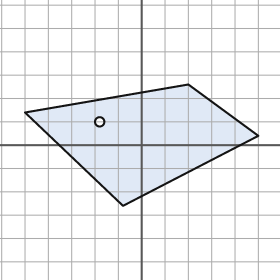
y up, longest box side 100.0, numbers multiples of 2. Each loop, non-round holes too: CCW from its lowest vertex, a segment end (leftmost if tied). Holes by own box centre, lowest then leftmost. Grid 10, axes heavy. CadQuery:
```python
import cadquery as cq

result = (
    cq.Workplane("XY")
    .moveTo(-8.0, -26.0)
    .lineTo(50.0, 4.0)
    .lineTo(20.0, 26.0)
    .lineTo(-50.0, 14.0)
    .close()
    .moveTo(-18.0, 10.0)
    .circle(2.0)
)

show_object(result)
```